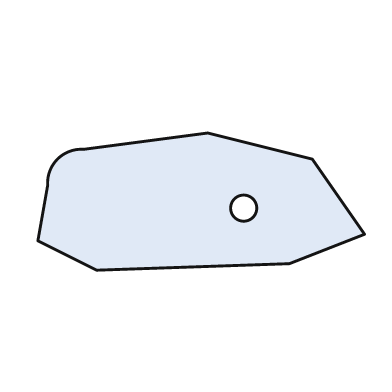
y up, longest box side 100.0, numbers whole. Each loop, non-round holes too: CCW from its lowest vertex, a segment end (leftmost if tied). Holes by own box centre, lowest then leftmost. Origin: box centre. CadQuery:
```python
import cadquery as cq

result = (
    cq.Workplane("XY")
    .moveTo(-32.0, -21.0)
    .lineTo(27.0, -19.0)
    .lineTo(50.0, -10.0)
    .lineTo(34.0, 13.0)
    .lineTo(2.0, 21.0)
    .lineTo(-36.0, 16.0)
    .threePointArc((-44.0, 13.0), (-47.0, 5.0))
    .lineTo(-50.0, -12.0)
    .close()
    .moveTo(13.0, -2.0)
    .circle(4.0)
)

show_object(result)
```